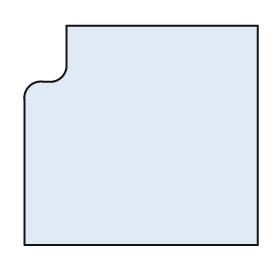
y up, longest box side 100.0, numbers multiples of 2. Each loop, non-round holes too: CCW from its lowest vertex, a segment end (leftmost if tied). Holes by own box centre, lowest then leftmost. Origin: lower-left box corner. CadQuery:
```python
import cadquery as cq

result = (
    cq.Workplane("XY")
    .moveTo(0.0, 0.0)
    .lineTo(100.0, 0.0)
    .lineTo(100.0, 94.0)
    .lineTo(18.0, 94.0)
    .lineTo(18.0, 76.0)
    .threePointArc((16.0, 72.0), (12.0, 70.0))
    .lineTo(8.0, 70.0)
    .threePointArc((2.0, 68.0), (0.0, 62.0))
    .close()
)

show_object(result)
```